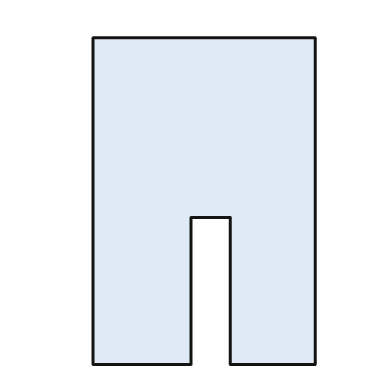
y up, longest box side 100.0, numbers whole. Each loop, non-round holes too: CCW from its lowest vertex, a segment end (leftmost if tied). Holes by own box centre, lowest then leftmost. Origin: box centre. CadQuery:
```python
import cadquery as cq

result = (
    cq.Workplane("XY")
    .moveTo(-34.0, -50.0)
    .lineTo(-4.0, -50.0)
    .lineTo(-4.0, -5.0)
    .lineTo(8.0, -5.0)
    .lineTo(8.0, -50.0)
    .lineTo(34.0, -50.0)
    .lineTo(34.0, 50.0)
    .lineTo(-34.0, 50.0)
    .close()
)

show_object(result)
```